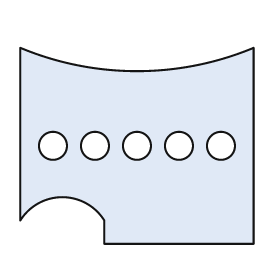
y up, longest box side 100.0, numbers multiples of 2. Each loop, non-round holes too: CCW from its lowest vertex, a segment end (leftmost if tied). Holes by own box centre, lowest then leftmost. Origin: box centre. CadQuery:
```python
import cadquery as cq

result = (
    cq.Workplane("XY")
    .moveTo(-14.0, -42.0)
    .lineTo(50.0, -42.0)
    .lineTo(50.0, 42.0)
    .threePointArc((0.0, 32.0), (-50.0, 42.0))
    .lineTo(-50.0, -32.0)
    .threePointArc((-32.0, -22.0), (-14.0, -32.0))
    .close()
    .moveTo(-36.0, 0.0)
    .circle(6.0)
    .moveTo(-18.0, 0.0)
    .circle(6.0)
    .moveTo(0.0, 0.0)
    .circle(6.0)
    .moveTo(18.0, 0.0)
    .circle(6.0)
    .moveTo(36.0, 0.0)
    .circle(6.0)
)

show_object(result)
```